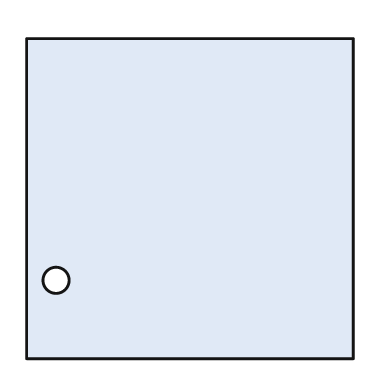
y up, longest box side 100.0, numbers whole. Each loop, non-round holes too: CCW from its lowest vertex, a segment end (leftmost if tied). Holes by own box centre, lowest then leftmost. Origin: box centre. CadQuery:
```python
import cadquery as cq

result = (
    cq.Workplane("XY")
    .moveTo(-50.0, -49.0)
    .lineTo(50.0, -49.0)
    .lineTo(50.0, 49.0)
    .lineTo(-50.0, 49.0)
    .close()
    .moveTo(-41.0, -25.0)
    .circle(4.0)
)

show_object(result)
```